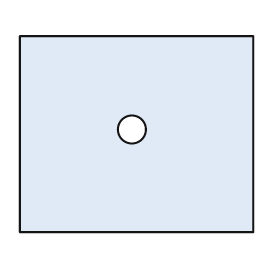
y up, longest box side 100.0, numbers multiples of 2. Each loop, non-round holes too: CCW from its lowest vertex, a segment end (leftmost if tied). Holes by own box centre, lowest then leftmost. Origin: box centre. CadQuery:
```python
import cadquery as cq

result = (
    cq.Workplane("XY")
    .moveTo(-50.0, -42.0)
    .lineTo(50.0, -42.0)
    .lineTo(50.0, 42.0)
    .lineTo(-50.0, 42.0)
    .close()
    .moveTo(-2.0, 2.0)
    .circle(6.0)
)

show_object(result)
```